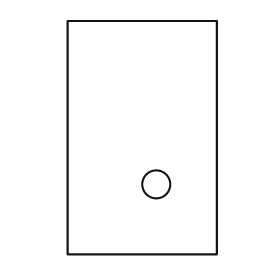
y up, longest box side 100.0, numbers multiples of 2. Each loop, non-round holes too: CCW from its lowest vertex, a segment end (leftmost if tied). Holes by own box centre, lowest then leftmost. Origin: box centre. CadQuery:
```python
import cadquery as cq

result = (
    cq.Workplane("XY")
    .moveTo(-32.0, -50.0)
    .lineTo(32.0, -50.0)
    .lineTo(32.0, 50.0)
    .lineTo(-32.0, 50.0)
    .close()
    .moveTo(6.0, -20.0)
    .circle(6.0)
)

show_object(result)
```